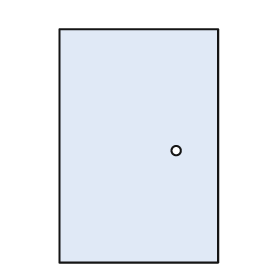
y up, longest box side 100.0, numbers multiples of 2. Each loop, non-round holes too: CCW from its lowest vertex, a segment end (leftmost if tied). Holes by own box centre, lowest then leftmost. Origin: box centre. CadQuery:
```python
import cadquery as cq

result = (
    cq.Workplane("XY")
    .moveTo(-34.0, -50.0)
    .lineTo(34.0, -50.0)
    .lineTo(34.0, 50.0)
    .lineTo(-34.0, 50.0)
    .close()
    .moveTo(16.0, -2.0)
    .circle(2.0)
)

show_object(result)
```